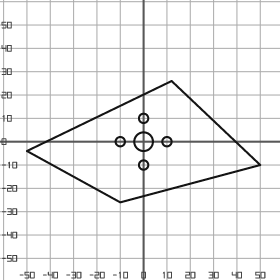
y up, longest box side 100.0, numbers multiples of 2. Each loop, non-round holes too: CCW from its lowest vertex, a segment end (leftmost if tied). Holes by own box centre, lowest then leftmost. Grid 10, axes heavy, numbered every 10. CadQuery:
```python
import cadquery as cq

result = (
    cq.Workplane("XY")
    .moveTo(-10.0, -26.0)
    .lineTo(50.0, -10.0)
    .lineTo(12.0, 26.0)
    .lineTo(-50.0, -4.0)
    .close()
    .moveTo(0.0, -10.0)
    .circle(2.0)
    .moveTo(-10.0, 0.0)
    .circle(2.0)
    .moveTo(0.0, 0.0)
    .circle(4.0)
    .moveTo(10.0, 0.0)
    .circle(2.0)
    .moveTo(0.0, 10.0)
    .circle(2.0)
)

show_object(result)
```